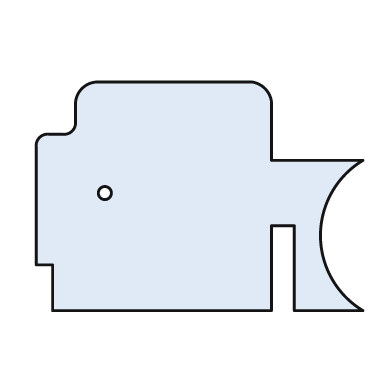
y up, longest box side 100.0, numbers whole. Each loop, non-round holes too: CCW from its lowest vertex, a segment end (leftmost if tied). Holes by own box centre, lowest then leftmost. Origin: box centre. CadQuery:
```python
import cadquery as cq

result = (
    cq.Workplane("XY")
    .moveTo(-45.0, -35.0)
    .lineTo(22.0, -35.0)
    .lineTo(22.0, -9.0)
    .lineTo(29.0, -9.0)
    .lineTo(29.0, -35.0)
    .lineTo(50.0, -35.0)
    .threePointArc((37.0, -12.0), (50.0, 11.0))
    .lineTo(22.0, 11.0)
    .lineTo(22.0, 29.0)
    .threePointArc((20.0, 33.0), (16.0, 35.0))
    .lineTo(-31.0, 35.0)
    .threePointArc((-36.0, 33.0), (-38.0, 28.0))
    .lineTo(-38.0, 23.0)
    .threePointArc((-39.0, 20.0), (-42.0, 19.0))
    .lineTo(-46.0, 19.0)
    .threePointArc((-49.0, 18.0), (-50.0, 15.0))
    .lineTo(-50.0, -21.0)
    .lineTo(-45.0, -21.0)
    .close()
    .moveTo(-29.0, 1.0)
    .circle(2.0)
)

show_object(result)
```